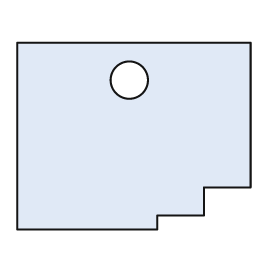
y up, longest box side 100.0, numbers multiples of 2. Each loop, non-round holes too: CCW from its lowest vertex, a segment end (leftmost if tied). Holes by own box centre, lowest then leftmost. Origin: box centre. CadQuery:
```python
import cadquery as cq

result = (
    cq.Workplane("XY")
    .moveTo(-50.0, -40.0)
    .lineTo(10.0, -40.0)
    .lineTo(10.0, -34.0)
    .lineTo(30.0, -34.0)
    .lineTo(30.0, -22.0)
    .lineTo(50.0, -22.0)
    .lineTo(50.0, 40.0)
    .lineTo(-50.0, 40.0)
    .close()
    .moveTo(-2.0, 24.0)
    .circle(8.0)
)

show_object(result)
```